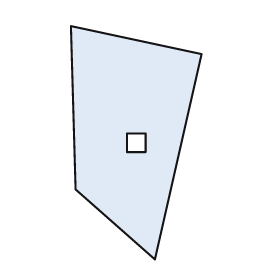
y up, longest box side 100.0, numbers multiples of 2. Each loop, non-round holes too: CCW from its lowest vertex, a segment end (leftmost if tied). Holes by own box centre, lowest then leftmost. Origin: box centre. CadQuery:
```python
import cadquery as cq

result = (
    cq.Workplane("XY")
    .moveTo(8.0, -50.0)
    .lineTo(28.0, 38.0)
    .lineTo(-28.0, 50.0)
    .lineTo(-26.0, -20.0)
    .close()
    .moveTo(-4.0, -4.0)
    .lineTo(4.0, -4.0)
    .lineTo(4.0, 4.0)
    .lineTo(-4.0, 4.0)
    .close()
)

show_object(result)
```